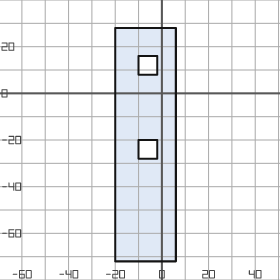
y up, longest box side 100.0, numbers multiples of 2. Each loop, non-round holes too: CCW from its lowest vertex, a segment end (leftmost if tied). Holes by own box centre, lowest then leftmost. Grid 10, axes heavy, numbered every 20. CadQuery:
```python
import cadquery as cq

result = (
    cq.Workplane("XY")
    .moveTo(-20.0, -72.0)
    .lineTo(6.0, -72.0)
    .lineTo(6.0, 28.0)
    .lineTo(-20.0, 28.0)
    .close()
    .moveTo(-10.0, -28.0)
    .lineTo(-2.0, -28.0)
    .lineTo(-2.0, -20.0)
    .lineTo(-10.0, -20.0)
    .close()
    .moveTo(-10.0, 8.0)
    .lineTo(-2.0, 8.0)
    .lineTo(-2.0, 16.0)
    .lineTo(-10.0, 16.0)
    .close()
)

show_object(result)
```